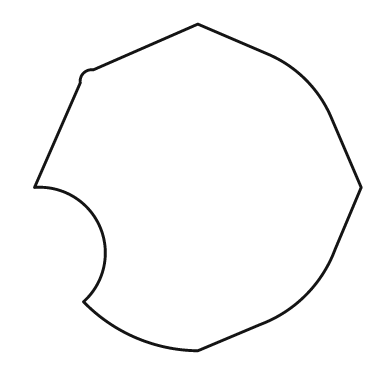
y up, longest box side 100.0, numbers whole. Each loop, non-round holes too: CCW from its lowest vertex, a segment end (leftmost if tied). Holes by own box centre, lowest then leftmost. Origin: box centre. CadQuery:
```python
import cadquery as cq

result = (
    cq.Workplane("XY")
    .moveTo(0.0, -50.0)
    .lineTo(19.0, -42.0)
    .threePointArc((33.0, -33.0), (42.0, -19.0))
    .lineTo(50.0, 0.0)
    .lineTo(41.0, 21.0)
    .threePointArc((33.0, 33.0), (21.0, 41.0))
    .lineTo(0.0, 50.0)
    .lineTo(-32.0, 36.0)
    .threePointArc((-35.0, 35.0), (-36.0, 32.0))
    .lineTo(-50.0, 0.0)
    .threePointArc((-30.0, -12.0), (-35.0, -35.0))
    .threePointArc((-19.0, -46.0), (0.0, -50.0))
    .close()
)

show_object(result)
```